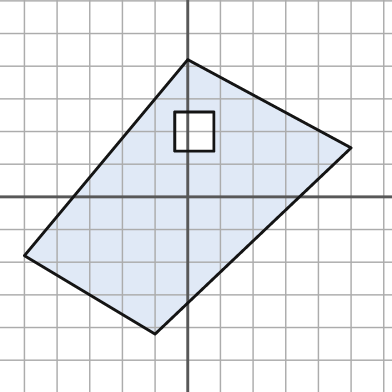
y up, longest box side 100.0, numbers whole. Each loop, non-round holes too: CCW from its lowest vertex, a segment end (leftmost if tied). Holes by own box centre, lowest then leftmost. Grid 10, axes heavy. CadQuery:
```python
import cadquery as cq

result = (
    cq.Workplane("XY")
    .moveTo(-10.0, -42.0)
    .lineTo(50.0, 15.0)
    .lineTo(0.0, 42.0)
    .lineTo(-50.0, -18.0)
    .close()
    .moveTo(-4.0, 14.0)
    .lineTo(8.0, 14.0)
    .lineTo(8.0, 26.0)
    .lineTo(-4.0, 26.0)
    .close()
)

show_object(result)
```